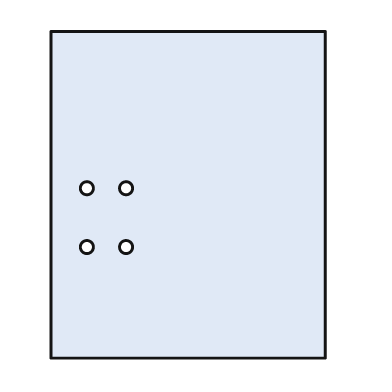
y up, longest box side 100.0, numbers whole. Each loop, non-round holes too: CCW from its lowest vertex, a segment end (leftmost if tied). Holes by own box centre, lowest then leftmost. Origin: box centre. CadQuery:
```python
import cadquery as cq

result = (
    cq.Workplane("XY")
    .moveTo(-42.0, -50.0)
    .lineTo(42.0, -50.0)
    .lineTo(42.0, 50.0)
    .lineTo(-42.0, 50.0)
    .close()
    .moveTo(-31.0, -16.0)
    .circle(2.0)
    .moveTo(-19.0, -16.0)
    .circle(2.0)
    .moveTo(-31.0, 2.0)
    .circle(2.0)
    .moveTo(-19.0, 2.0)
    .circle(2.0)
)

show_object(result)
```